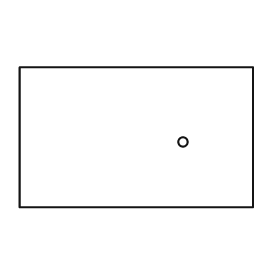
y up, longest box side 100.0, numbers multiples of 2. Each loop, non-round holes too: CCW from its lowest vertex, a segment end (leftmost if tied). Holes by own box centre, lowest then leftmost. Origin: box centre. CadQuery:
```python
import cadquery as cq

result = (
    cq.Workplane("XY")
    .moveTo(-50.0, -30.0)
    .lineTo(50.0, -30.0)
    .lineTo(50.0, 30.0)
    .lineTo(-50.0, 30.0)
    .close()
    .moveTo(20.0, -2.0)
    .circle(2.0)
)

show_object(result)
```